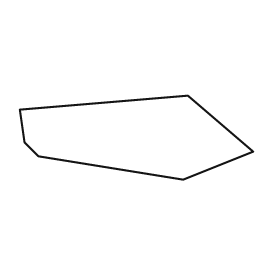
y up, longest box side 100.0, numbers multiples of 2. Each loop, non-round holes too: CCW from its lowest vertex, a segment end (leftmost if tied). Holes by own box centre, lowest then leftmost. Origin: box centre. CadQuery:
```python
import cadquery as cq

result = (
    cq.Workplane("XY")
    .moveTo(20.0, -18.0)
    .lineTo(50.0, -6.0)
    .lineTo(22.0, 18.0)
    .lineTo(-50.0, 12.0)
    .lineTo(-48.0, -2.0)
    .lineTo(-42.0, -8.0)
    .close()
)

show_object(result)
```